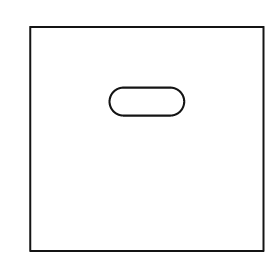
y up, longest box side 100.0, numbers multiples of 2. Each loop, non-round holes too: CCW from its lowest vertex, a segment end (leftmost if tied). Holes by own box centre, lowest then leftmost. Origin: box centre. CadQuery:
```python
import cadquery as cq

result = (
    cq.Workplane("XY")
    .moveTo(-50.0, -48.0)
    .lineTo(50.0, -48.0)
    .lineTo(50.0, 48.0)
    .lineTo(-50.0, 48.0)
    .close()
    .moveTo(-10.0, 10.0)
    .lineTo(10.0, 10.0)
    .threePointArc((16.0, 16.0), (10.0, 22.0))
    .lineTo(-10.0, 22.0)
    .threePointArc((-16.0, 16.0), (-10.0, 10.0))
    .close()
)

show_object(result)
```